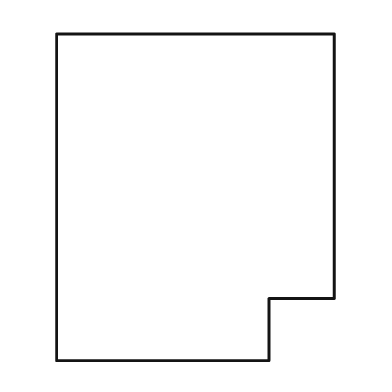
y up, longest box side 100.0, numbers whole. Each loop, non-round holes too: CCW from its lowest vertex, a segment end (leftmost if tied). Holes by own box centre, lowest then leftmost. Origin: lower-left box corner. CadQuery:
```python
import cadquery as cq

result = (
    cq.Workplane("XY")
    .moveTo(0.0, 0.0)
    .lineTo(65.0, 0.0)
    .lineTo(65.0, 19.0)
    .lineTo(85.0, 19.0)
    .lineTo(85.0, 100.0)
    .lineTo(0.0, 100.0)
    .close()
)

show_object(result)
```